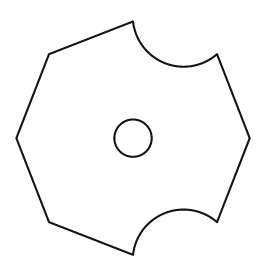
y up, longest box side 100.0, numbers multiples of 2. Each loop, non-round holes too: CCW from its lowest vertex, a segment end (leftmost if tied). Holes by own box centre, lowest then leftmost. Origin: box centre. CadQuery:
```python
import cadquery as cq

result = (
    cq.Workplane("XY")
    .moveTo(0.0, -50.0)
    .threePointArc((14.0, -32.0), (36.0, -36.0))
    .lineTo(50.0, 0.0)
    .lineTo(36.0, 36.0)
    .threePointArc((14.0, 32.0), (0.0, 50.0))
    .lineTo(-36.0, 36.0)
    .lineTo(-50.0, 0.0)
    .lineTo(-36.0, -36.0)
    .close()
    .moveTo(0.0, 0.0)
    .circle(8.0)
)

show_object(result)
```